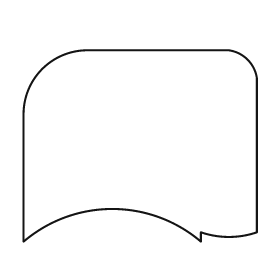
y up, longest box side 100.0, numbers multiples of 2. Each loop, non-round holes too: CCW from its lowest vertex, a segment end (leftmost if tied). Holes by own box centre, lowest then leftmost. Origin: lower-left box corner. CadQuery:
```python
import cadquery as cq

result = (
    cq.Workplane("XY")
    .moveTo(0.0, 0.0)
    .threePointArc((38.0, 14.0), (76.0, 0.0))
    .lineTo(76.0, 4.0)
    .threePointArc((88.0, 2.0), (100.0, 4.0))
    .lineTo(100.0, 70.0)
    .threePointArc((96.0, 78.0), (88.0, 82.0))
    .lineTo(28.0, 82.0)
    .threePointArc((8.0, 74.0), (0.0, 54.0))
    .close()
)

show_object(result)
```